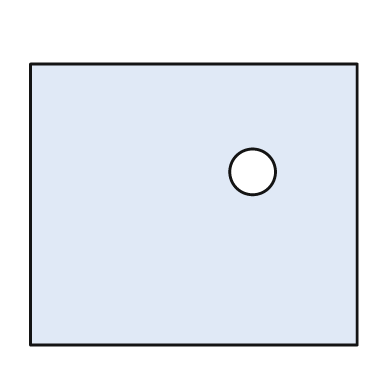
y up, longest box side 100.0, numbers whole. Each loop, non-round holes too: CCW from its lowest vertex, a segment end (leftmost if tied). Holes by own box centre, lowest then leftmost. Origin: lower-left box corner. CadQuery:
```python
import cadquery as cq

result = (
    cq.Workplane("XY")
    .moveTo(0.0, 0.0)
    .lineTo(100.0, 0.0)
    .lineTo(100.0, 86.0)
    .lineTo(0.0, 86.0)
    .close()
    .moveTo(68.0, 53.0)
    .circle(7.0)
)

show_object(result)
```